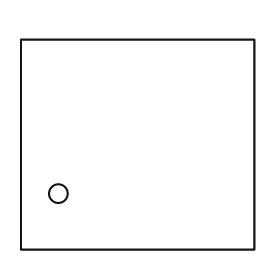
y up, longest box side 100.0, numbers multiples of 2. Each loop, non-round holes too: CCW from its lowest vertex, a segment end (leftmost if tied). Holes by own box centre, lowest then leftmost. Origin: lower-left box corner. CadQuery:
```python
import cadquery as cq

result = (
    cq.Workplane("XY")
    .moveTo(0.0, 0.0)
    .lineTo(100.0, 0.0)
    .lineTo(100.0, 90.0)
    .lineTo(0.0, 90.0)
    .close()
    .moveTo(16.0, 24.0)
    .circle(4.0)
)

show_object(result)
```